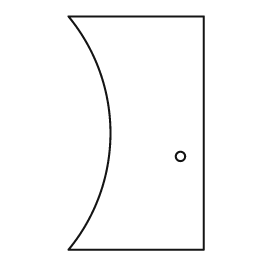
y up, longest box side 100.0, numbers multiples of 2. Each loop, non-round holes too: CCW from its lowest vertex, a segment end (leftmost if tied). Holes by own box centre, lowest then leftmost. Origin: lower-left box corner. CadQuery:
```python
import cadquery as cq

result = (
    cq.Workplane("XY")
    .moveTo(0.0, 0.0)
    .lineTo(58.0, 0.0)
    .lineTo(58.0, 100.0)
    .lineTo(0.0, 100.0)
    .threePointArc((18.0, 50.0), (0.0, 0.0))
    .close()
    .moveTo(48.0, 40.0)
    .circle(2.0)
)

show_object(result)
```